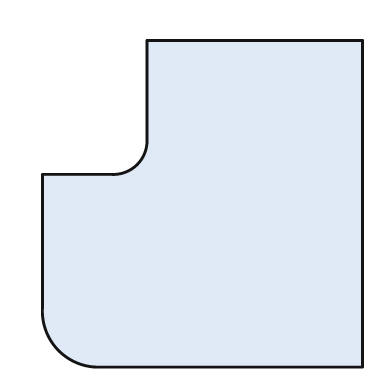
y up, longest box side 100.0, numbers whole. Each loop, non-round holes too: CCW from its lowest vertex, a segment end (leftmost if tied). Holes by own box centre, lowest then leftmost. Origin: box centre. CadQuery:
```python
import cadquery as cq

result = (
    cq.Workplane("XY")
    .moveTo(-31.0, -50.0)
    .lineTo(49.0, -50.0)
    .lineTo(49.0, 50.0)
    .lineTo(-17.0, 50.0)
    .lineTo(-17.0, 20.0)
    .threePointArc((-20.0, 12.0), (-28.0, 9.0))
    .lineTo(-49.0, 9.0)
    .lineTo(-49.0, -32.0)
    .threePointArc((-44.0, -45.0), (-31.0, -50.0))
    .close()
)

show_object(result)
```